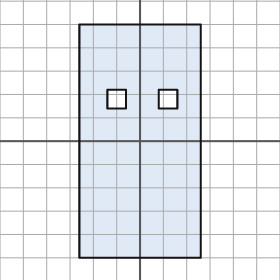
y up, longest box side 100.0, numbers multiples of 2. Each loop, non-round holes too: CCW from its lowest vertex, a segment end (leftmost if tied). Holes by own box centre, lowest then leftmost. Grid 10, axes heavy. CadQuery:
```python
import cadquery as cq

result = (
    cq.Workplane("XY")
    .moveTo(-26.0, -50.0)
    .lineTo(26.0, -50.0)
    .lineTo(26.0, 50.0)
    .lineTo(-26.0, 50.0)
    .close()
    .moveTo(-14.0, 14.0)
    .lineTo(-6.0, 14.0)
    .lineTo(-6.0, 22.0)
    .lineTo(-14.0, 22.0)
    .close()
    .moveTo(8.0, 14.0)
    .lineTo(16.0, 14.0)
    .lineTo(16.0, 22.0)
    .lineTo(8.0, 22.0)
    .close()
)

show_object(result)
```